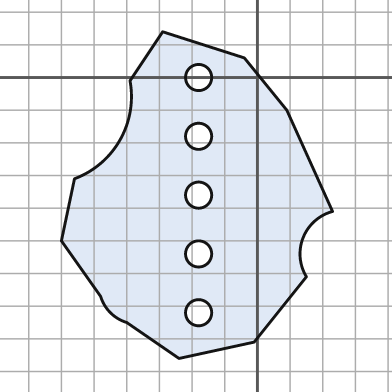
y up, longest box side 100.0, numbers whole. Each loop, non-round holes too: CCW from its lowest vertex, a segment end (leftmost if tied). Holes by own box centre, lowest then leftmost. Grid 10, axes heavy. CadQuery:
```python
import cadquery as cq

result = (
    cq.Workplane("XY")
    .moveTo(-24.0, -86.0)
    .lineTo(-1.0, -81.0)
    .lineTo(15.0, -61.0)
    .threePointArc((14.0, -49.0), (23.0, -41.0))
    .lineTo(9.0, -10.0)
    .lineTo(-4.0, 6.0)
    .lineTo(-29.0, 14.0)
    .lineTo(-39.0, -1.0)
    .threePointArc((-42.0, -19.0), (-56.0, -31.0))
    .lineTo(-60.0, -50.0)
    .lineTo(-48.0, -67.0)
    .threePointArc((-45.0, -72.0), (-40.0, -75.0))
    .close()
    .moveTo(-18.0, -72.0)
    .circle(4.0)
    .moveTo(-18.0, -54.0)
    .circle(4.0)
    .moveTo(-18.0, -36.0)
    .circle(4.0)
    .moveTo(-18.0, -18.0)
    .circle(4.0)
    .moveTo(-18.0, 0.0)
    .circle(4.0)
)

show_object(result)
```